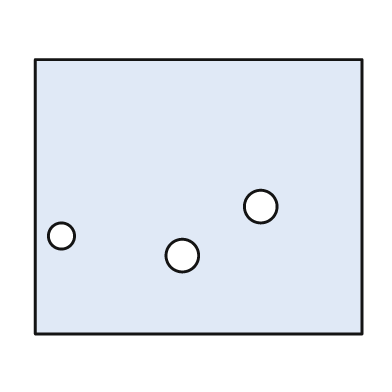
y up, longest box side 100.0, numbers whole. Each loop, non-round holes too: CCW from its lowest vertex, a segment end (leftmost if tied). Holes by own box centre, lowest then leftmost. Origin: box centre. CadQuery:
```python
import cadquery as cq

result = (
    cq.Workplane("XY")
    .moveTo(-50.0, -42.0)
    .lineTo(50.0, -42.0)
    .lineTo(50.0, 42.0)
    .lineTo(-50.0, 42.0)
    .close()
    .moveTo(-5.0, -18.0)
    .circle(5.0)
    .moveTo(-42.0, -12.0)
    .circle(4.0)
    .moveTo(19.0, -3.0)
    .circle(5.0)
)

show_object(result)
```